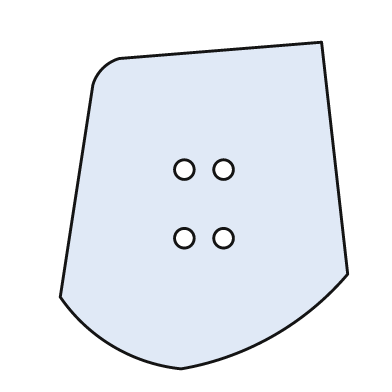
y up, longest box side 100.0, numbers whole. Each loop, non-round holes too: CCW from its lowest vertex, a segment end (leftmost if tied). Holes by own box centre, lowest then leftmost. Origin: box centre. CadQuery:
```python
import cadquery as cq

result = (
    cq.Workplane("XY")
    .moveTo(-7.0, -50.0)
    .threePointArc((21.0, -40.0), (44.0, -21.0))
    .lineTo(36.0, 50.0)
    .lineTo(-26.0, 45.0)
    .threePointArc((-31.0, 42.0), (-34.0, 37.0))
    .lineTo(-44.0, -28.0)
    .threePointArc((-28.0, -43.0), (-7.0, -50.0))
    .close()
    .moveTo(-6.0, -10.0)
    .circle(3.0)
    .moveTo(6.0, -10.0)
    .circle(3.0)
    .moveTo(-6.0, 11.0)
    .circle(3.0)
    .moveTo(6.0, 11.0)
    .circle(3.0)
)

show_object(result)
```